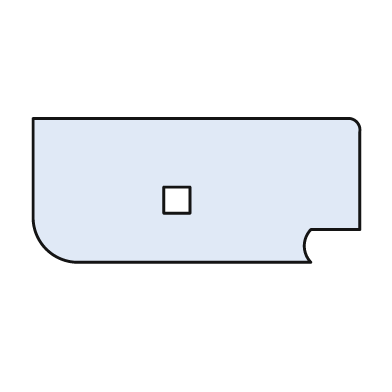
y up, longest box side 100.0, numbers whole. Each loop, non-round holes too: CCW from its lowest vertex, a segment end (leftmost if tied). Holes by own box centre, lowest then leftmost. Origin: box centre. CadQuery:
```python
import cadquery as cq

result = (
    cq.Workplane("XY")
    .moveTo(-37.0, -22.0)
    .lineTo(35.0, -22.0)
    .threePointArc((33.0, -17.0), (35.0, -12.0))
    .lineTo(50.0, -12.0)
    .lineTo(50.0, 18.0)
    .threePointArc((49.0, 21.0), (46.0, 22.0))
    .lineTo(-50.0, 22.0)
    .lineTo(-50.0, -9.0)
    .threePointArc((-46.0, -18.0), (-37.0, -22.0))
    .close()
    .moveTo(-10.0, -7.0)
    .lineTo(-2.0, -7.0)
    .lineTo(-2.0, 1.0)
    .lineTo(-10.0, 1.0)
    .close()
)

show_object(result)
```